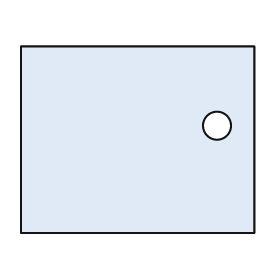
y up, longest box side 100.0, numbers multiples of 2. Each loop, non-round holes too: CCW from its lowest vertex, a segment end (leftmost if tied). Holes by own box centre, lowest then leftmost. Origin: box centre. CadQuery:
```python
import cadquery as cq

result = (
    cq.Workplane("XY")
    .moveTo(-50.0, -40.0)
    .lineTo(50.0, -40.0)
    .lineTo(50.0, 40.0)
    .lineTo(-50.0, 40.0)
    .close()
    .moveTo(34.0, 6.0)
    .circle(6.0)
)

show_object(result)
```